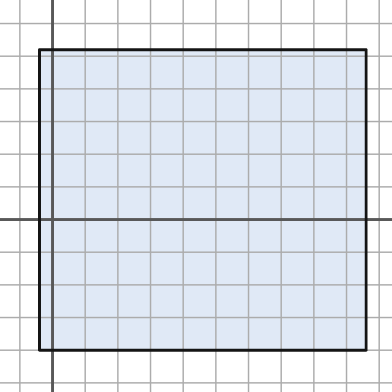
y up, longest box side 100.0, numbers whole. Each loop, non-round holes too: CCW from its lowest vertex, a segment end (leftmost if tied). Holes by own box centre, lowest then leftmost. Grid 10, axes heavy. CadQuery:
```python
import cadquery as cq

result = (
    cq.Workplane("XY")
    .moveTo(-4.0, -40.0)
    .lineTo(96.0, -40.0)
    .lineTo(96.0, 52.0)
    .lineTo(-4.0, 52.0)
    .close()
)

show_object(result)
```